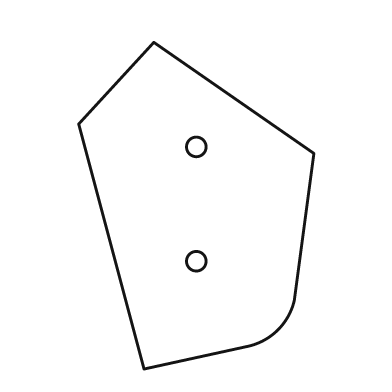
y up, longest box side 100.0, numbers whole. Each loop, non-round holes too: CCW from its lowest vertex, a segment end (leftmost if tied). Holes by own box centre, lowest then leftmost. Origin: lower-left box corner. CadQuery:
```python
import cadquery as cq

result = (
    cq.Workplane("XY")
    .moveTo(20.0, 0.0)
    .lineTo(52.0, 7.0)
    .threePointArc((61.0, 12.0), (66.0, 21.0))
    .lineTo(72.0, 66.0)
    .lineTo(23.0, 100.0)
    .lineTo(0.0, 75.0)
    .close()
    .moveTo(36.0, 33.0)
    .circle(3.0)
    .moveTo(36.0, 68.0)
    .circle(3.0)
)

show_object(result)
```